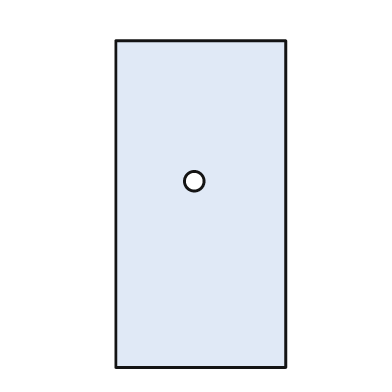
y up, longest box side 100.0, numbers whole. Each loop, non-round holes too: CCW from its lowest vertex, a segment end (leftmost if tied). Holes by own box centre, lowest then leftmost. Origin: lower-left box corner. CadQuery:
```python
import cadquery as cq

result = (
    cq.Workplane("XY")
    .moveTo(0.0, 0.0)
    .lineTo(52.0, 0.0)
    .lineTo(52.0, 100.0)
    .lineTo(0.0, 100.0)
    .close()
    .moveTo(24.0, 57.0)
    .circle(3.0)
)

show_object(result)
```